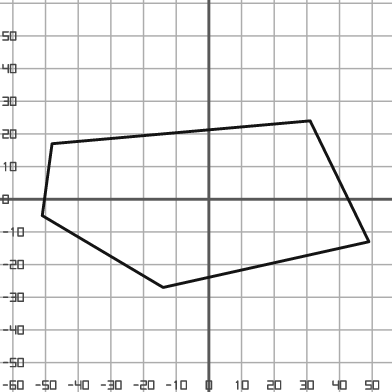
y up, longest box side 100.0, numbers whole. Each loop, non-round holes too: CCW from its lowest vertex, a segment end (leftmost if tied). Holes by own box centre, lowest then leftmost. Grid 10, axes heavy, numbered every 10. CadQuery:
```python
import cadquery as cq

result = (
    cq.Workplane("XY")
    .moveTo(-14.0, -27.0)
    .lineTo(49.0, -13.0)
    .lineTo(31.0, 24.0)
    .lineTo(-48.0, 17.0)
    .lineTo(-51.0, -5.0)
    .close()
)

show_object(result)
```